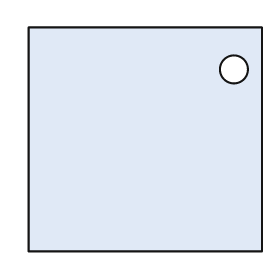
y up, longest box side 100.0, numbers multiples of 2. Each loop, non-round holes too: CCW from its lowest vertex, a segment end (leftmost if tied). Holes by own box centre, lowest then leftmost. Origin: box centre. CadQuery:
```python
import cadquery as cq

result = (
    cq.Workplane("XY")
    .moveTo(-50.0, -48.0)
    .lineTo(50.0, -48.0)
    .lineTo(50.0, 48.0)
    .lineTo(-50.0, 48.0)
    .close()
    .moveTo(38.0, 30.0)
    .circle(6.0)
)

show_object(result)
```